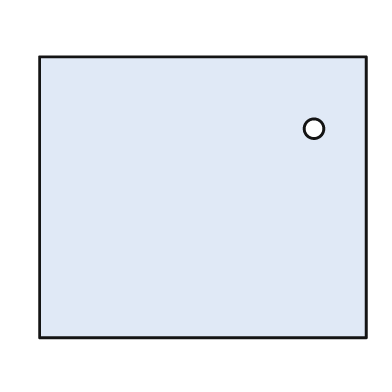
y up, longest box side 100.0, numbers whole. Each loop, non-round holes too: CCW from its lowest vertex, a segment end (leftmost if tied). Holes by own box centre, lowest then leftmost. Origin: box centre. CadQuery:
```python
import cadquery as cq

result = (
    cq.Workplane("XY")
    .moveTo(-50.0, -43.0)
    .lineTo(50.0, -43.0)
    .lineTo(50.0, 43.0)
    .lineTo(-50.0, 43.0)
    .close()
    .moveTo(34.0, 21.0)
    .circle(3.0)
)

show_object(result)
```